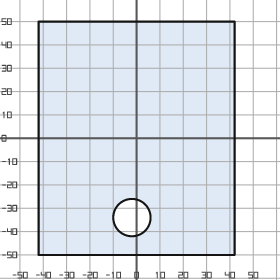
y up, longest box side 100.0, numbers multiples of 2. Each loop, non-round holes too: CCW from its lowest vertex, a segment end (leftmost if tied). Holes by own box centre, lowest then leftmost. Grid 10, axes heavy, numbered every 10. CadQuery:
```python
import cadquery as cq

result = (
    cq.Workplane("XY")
    .moveTo(-42.0, -50.0)
    .lineTo(42.0, -50.0)
    .lineTo(42.0, 50.0)
    .lineTo(-42.0, 50.0)
    .close()
    .moveTo(-2.0, -34.0)
    .circle(8.0)
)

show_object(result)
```